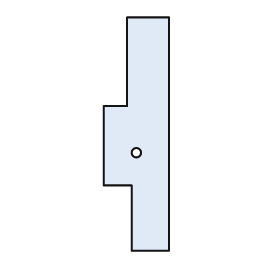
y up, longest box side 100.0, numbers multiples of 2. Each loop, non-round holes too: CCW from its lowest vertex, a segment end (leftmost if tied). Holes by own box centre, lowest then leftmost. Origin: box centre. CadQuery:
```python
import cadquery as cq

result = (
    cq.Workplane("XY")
    .moveTo(-2.0, -50.0)
    .lineTo(14.0, -50.0)
    .lineTo(14.0, 50.0)
    .lineTo(-4.0, 50.0)
    .lineTo(-4.0, 12.0)
    .lineTo(-14.0, 12.0)
    .lineTo(-14.0, -22.0)
    .lineTo(-2.0, -22.0)
    .close()
    .moveTo(0.0, -8.0)
    .circle(2.0)
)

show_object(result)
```